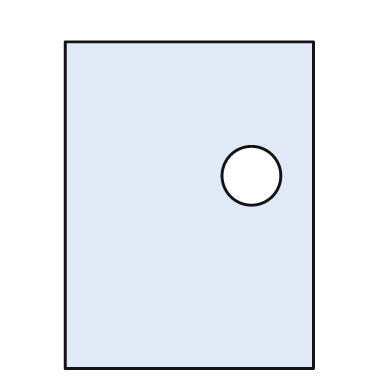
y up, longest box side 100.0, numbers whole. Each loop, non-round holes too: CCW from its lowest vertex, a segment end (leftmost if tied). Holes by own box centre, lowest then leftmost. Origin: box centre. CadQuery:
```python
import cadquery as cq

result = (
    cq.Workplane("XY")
    .moveTo(-38.0, -50.0)
    .lineTo(38.0, -50.0)
    .lineTo(38.0, 50.0)
    .lineTo(-38.0, 50.0)
    .close()
    .moveTo(19.0, 9.0)
    .circle(9.0)
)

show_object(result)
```